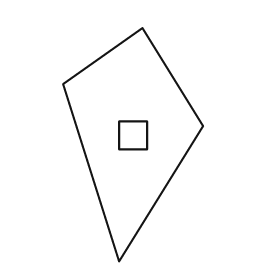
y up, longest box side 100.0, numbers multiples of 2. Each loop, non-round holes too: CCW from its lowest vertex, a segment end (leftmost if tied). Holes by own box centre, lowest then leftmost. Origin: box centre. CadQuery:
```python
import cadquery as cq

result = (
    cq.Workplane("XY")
    .moveTo(-6.0, -50.0)
    .lineTo(30.0, 8.0)
    .lineTo(4.0, 50.0)
    .lineTo(-30.0, 26.0)
    .close()
    .moveTo(-6.0, -2.0)
    .lineTo(6.0, -2.0)
    .lineTo(6.0, 10.0)
    .lineTo(-6.0, 10.0)
    .close()
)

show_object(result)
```